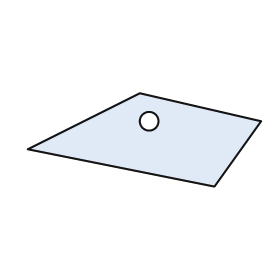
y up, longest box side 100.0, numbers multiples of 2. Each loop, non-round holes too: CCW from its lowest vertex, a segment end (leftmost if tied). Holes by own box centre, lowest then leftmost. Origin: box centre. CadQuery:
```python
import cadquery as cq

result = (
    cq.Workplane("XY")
    .moveTo(30.0, -20.0)
    .lineTo(50.0, 8.0)
    .lineTo(-2.0, 20.0)
    .lineTo(-50.0, -4.0)
    .close()
    .moveTo(2.0, 8.0)
    .circle(4.0)
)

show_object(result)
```